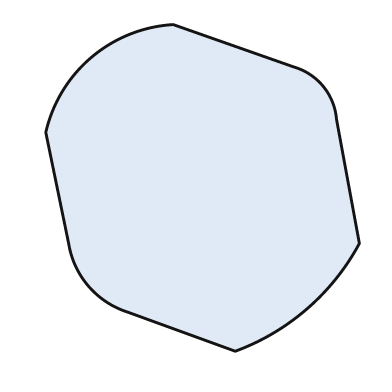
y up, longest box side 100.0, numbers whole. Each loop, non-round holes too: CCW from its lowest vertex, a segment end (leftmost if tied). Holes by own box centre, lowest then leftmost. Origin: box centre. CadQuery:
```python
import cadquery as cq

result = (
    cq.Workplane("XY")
    .moveTo(10.0, -50.0)
    .threePointArc((32.0, -37.0), (48.0, -17.0))
    .lineTo(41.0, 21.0)
    .threePointArc((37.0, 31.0), (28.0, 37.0))
    .lineTo(-9.0, 50.0)
    .threePointArc((-34.0, 40.0), (-48.0, 17.0))
    .lineTo(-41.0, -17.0)
    .threePointArc((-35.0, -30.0), (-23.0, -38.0))
    .close()
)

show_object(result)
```